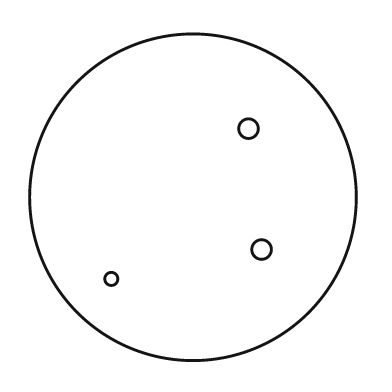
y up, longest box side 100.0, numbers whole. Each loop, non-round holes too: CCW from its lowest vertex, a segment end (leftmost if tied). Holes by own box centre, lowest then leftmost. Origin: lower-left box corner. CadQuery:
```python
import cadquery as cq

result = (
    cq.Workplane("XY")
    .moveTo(50.0, 50.0)
    .circle(50.0)
    .moveTo(25.0, 25.0)
    .circle(2.0)
    .moveTo(71.0, 34.0)
    .circle(3.0)
    .moveTo(67.0, 71.0)
    .circle(3.0)
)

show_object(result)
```